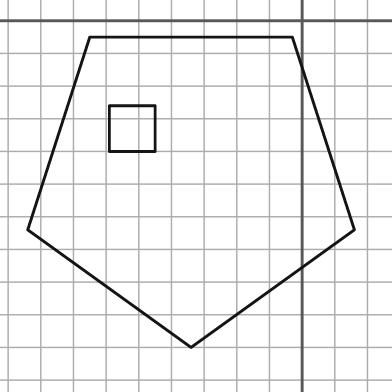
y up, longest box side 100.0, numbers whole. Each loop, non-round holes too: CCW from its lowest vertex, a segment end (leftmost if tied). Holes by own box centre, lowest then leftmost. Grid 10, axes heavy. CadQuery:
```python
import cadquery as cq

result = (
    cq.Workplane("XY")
    .moveTo(-34.0, -100.0)
    .lineTo(16.0, -64.0)
    .lineTo(-3.0, -5.0)
    .lineTo(-65.0, -5.0)
    .lineTo(-84.0, -64.0)
    .close()
    .moveTo(-59.0, -40.0)
    .lineTo(-45.0, -40.0)
    .lineTo(-45.0, -26.0)
    .lineTo(-59.0, -26.0)
    .close()
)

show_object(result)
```